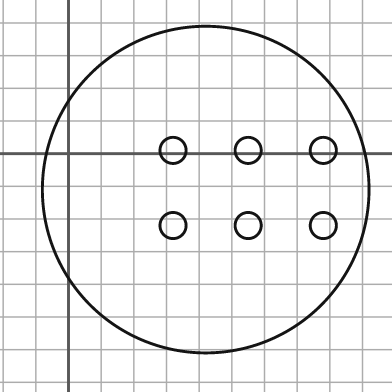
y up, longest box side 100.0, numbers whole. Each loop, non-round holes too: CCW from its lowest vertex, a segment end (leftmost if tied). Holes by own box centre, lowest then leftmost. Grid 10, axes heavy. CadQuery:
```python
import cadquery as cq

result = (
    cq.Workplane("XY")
    .moveTo(42.0, -11.0)
    .circle(50.0)
    .moveTo(32.0, -22.0)
    .circle(4.0)
    .moveTo(55.0, -22.0)
    .circle(4.0)
    .moveTo(78.0, -22.0)
    .circle(4.0)
    .moveTo(32.0, 1.0)
    .circle(4.0)
    .moveTo(55.0, 1.0)
    .circle(4.0)
    .moveTo(78.0, 1.0)
    .circle(4.0)
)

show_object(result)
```